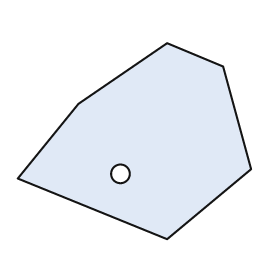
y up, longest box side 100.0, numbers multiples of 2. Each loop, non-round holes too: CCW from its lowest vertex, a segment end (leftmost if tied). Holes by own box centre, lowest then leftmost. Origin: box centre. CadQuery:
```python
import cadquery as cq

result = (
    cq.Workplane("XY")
    .moveTo(14.0, -42.0)
    .lineTo(50.0, -12.0)
    .lineTo(38.0, 32.0)
    .lineTo(14.0, 42.0)
    .lineTo(-24.0, 16.0)
    .lineTo(-50.0, -16.0)
    .close()
    .moveTo(-6.0, -14.0)
    .circle(4.0)
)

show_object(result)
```